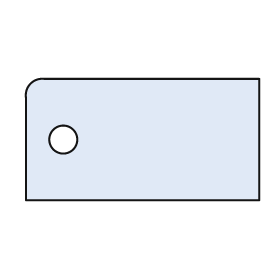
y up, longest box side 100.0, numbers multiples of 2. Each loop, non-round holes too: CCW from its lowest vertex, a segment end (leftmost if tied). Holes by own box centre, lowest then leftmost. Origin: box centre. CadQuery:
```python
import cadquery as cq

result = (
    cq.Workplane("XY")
    .moveTo(-50.0, -26.0)
    .lineTo(50.0, -26.0)
    .lineTo(50.0, 26.0)
    .lineTo(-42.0, 26.0)
    .threePointArc((-48.0, 24.0), (-50.0, 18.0))
    .close()
    .moveTo(-34.0, 0.0)
    .circle(6.0)
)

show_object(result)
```